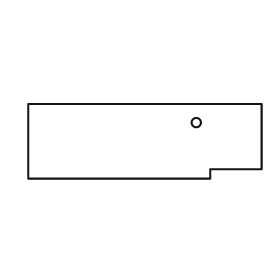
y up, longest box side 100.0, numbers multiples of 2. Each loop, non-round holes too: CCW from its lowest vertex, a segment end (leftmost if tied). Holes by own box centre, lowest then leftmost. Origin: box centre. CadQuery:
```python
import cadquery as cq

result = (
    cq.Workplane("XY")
    .moveTo(-50.0, -16.0)
    .lineTo(28.0, -16.0)
    .lineTo(28.0, -12.0)
    .lineTo(50.0, -12.0)
    .lineTo(50.0, 16.0)
    .lineTo(-50.0, 16.0)
    .close()
    .moveTo(22.0, 8.0)
    .circle(2.0)
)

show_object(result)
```